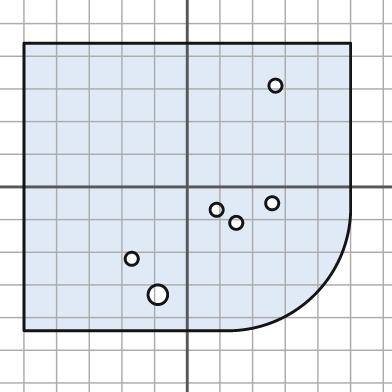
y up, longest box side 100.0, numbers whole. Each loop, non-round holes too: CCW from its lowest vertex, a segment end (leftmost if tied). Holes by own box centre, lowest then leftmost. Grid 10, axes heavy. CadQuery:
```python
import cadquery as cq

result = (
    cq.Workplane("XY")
    .moveTo(-50.0, -44.0)
    .lineTo(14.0, -44.0)
    .threePointArc((39.0, -33.0), (50.0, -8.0))
    .lineTo(50.0, 44.0)
    .lineTo(-50.0, 44.0)
    .close()
    .moveTo(-9.0, -33.0)
    .circle(3.0)
    .moveTo(-17.0, -22.0)
    .circle(2.0)
    .moveTo(15.0, -11.0)
    .circle(2.0)
    .moveTo(9.0, -7.0)
    .circle(2.0)
    .moveTo(26.0, -5.0)
    .circle(2.0)
    .moveTo(27.0, 31.0)
    .circle(2.0)
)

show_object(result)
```